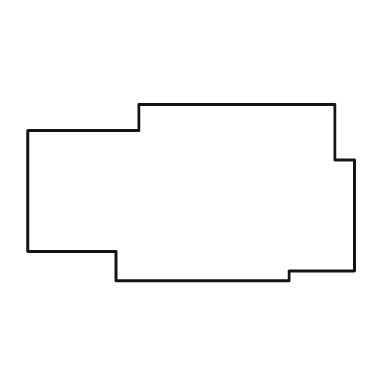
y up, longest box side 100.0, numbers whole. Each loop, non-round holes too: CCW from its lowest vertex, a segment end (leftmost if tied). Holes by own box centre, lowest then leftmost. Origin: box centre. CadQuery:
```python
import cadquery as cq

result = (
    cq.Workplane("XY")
    .moveTo(-23.0, -27.0)
    .lineTo(30.0, -27.0)
    .lineTo(30.0, -24.0)
    .lineTo(50.0, -24.0)
    .lineTo(50.0, 10.0)
    .lineTo(44.0, 10.0)
    .lineTo(44.0, 27.0)
    .lineTo(-16.0, 27.0)
    .lineTo(-16.0, 19.0)
    .lineTo(-50.0, 19.0)
    .lineTo(-50.0, -18.0)
    .lineTo(-23.0, -18.0)
    .close()
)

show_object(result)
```